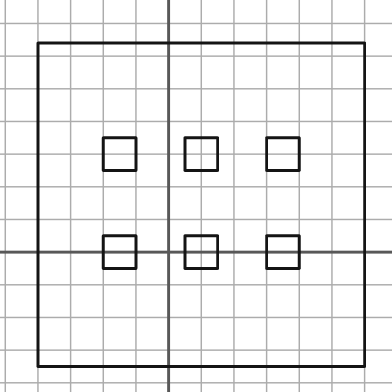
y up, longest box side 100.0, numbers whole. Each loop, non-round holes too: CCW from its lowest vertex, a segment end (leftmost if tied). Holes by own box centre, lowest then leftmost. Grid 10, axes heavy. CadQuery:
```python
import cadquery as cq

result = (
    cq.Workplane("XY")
    .moveTo(-40.0, -35.0)
    .lineTo(60.0, -35.0)
    .lineTo(60.0, 64.0)
    .lineTo(-40.0, 64.0)
    .close()
    .moveTo(-20.0, -5.0)
    .lineTo(-10.0, -5.0)
    .lineTo(-10.0, 5.0)
    .lineTo(-20.0, 5.0)
    .close()
    .moveTo(5.0, -5.0)
    .lineTo(15.0, -5.0)
    .lineTo(15.0, 5.0)
    .lineTo(5.0, 5.0)
    .close()
    .moveTo(30.0, -5.0)
    .lineTo(40.0, -5.0)
    .lineTo(40.0, 5.0)
    .lineTo(30.0, 5.0)
    .close()
    .moveTo(-20.0, 25.0)
    .lineTo(-10.0, 25.0)
    .lineTo(-10.0, 35.0)
    .lineTo(-20.0, 35.0)
    .close()
    .moveTo(5.0, 25.0)
    .lineTo(15.0, 25.0)
    .lineTo(15.0, 35.0)
    .lineTo(5.0, 35.0)
    .close()
    .moveTo(30.0, 25.0)
    .lineTo(40.0, 25.0)
    .lineTo(40.0, 35.0)
    .lineTo(30.0, 35.0)
    .close()
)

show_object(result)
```